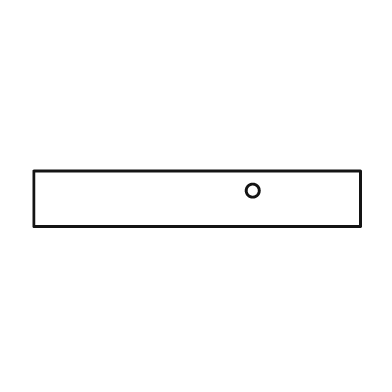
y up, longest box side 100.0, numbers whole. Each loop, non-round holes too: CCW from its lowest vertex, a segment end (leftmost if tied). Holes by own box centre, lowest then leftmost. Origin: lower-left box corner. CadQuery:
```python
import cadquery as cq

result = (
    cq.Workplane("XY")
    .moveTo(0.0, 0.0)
    .lineTo(100.0, 0.0)
    .lineTo(100.0, 17.0)
    .lineTo(0.0, 17.0)
    .close()
    .moveTo(67.0, 11.0)
    .circle(2.0)
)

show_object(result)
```